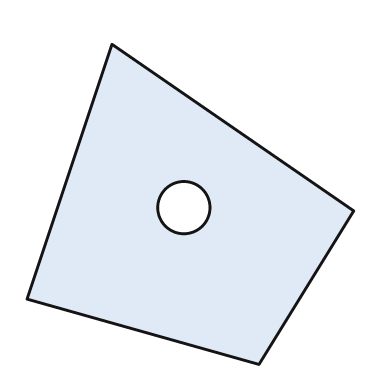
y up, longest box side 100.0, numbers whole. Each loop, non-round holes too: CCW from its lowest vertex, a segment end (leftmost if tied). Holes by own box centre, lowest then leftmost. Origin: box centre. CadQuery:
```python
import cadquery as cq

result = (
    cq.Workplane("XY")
    .moveTo(21.0, -49.0)
    .lineTo(50.0, -2.0)
    .lineTo(-24.0, 49.0)
    .lineTo(-50.0, -29.0)
    .close()
    .moveTo(-2.0, -1.0)
    .circle(8.0)
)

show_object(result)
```